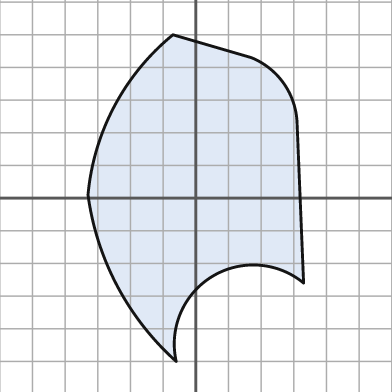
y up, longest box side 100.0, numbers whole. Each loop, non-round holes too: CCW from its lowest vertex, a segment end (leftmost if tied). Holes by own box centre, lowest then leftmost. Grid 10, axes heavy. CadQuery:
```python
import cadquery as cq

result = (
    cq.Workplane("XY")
    .moveTo(-6.0, -50.0)
    .threePointArc((5.0, -24.0), (33.0, -26.0))
    .lineTo(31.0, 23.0)
    .threePointArc((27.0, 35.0), (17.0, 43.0))
    .lineTo(-7.0, 50.0)
    .threePointArc((-25.0, 28.0), (-33.0, 1.0))
    .threePointArc((-24.0, -27.0), (-6.0, -50.0))
    .close()
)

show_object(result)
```